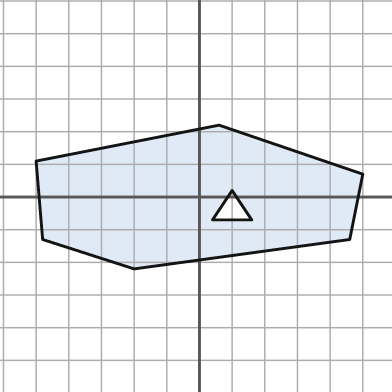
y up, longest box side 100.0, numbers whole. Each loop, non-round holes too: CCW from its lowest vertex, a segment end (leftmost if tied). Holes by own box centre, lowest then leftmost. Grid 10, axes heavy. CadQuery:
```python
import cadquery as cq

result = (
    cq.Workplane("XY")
    .moveTo(-20.0, -22.0)
    .lineTo(46.0, -13.0)
    .lineTo(50.0, 7.0)
    .lineTo(6.0, 22.0)
    .lineTo(-50.0, 11.0)
    .lineTo(-48.0, -13.0)
    .close()
    .moveTo(4.0, -7.0)
    .lineTo(16.0, -7.0)
    .lineTo(10.0, 2.0)
    .close()
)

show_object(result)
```